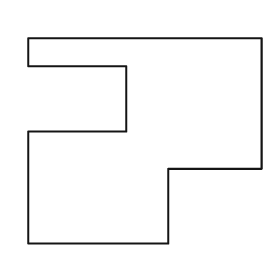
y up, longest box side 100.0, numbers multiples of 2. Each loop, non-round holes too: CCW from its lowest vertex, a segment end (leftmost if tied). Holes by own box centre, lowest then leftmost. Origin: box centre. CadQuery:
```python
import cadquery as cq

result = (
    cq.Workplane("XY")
    .moveTo(-50.0, -44.0)
    .lineTo(10.0, -44.0)
    .lineTo(10.0, -12.0)
    .lineTo(50.0, -12.0)
    .lineTo(50.0, 44.0)
    .lineTo(-50.0, 44.0)
    .lineTo(-50.0, 32.0)
    .lineTo(-8.0, 32.0)
    .lineTo(-8.0, 4.0)
    .lineTo(-50.0, 4.0)
    .close()
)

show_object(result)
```